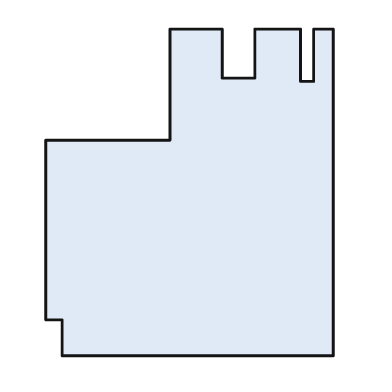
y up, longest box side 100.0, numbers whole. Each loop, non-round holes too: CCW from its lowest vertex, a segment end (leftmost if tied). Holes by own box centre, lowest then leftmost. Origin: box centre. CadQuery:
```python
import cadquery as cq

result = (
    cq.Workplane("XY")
    .moveTo(-39.0, -50.0)
    .lineTo(44.0, -50.0)
    .lineTo(44.0, 50.0)
    .lineTo(38.0, 50.0)
    .lineTo(38.0, 34.0)
    .lineTo(34.0, 34.0)
    .lineTo(34.0, 50.0)
    .lineTo(20.0, 50.0)
    .lineTo(20.0, 35.0)
    .lineTo(10.0, 35.0)
    .lineTo(10.0, 50.0)
    .lineTo(-6.0, 50.0)
    .lineTo(-6.0, 16.0)
    .lineTo(-44.0, 16.0)
    .lineTo(-44.0, -39.0)
    .lineTo(-39.0, -39.0)
    .close()
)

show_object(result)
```